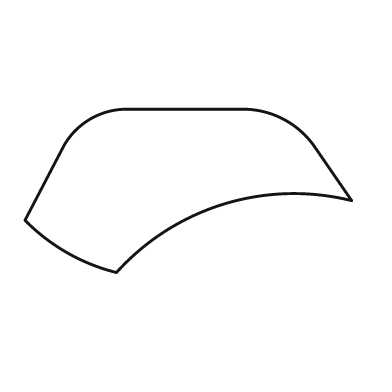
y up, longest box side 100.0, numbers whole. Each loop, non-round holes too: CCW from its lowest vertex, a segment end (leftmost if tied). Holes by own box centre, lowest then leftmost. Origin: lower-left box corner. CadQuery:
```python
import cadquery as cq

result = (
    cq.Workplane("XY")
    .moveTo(28.0, 0.0)
    .threePointArc((61.0, 21.0), (100.0, 22.0))
    .lineTo(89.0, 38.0)
    .threePointArc((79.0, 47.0), (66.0, 50.0))
    .lineTo(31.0, 50.0)
    .threePointArc((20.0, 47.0), (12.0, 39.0))
    .lineTo(0.0, 16.0)
    .threePointArc((13.0, 6.0), (28.0, 0.0))
    .close()
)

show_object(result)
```